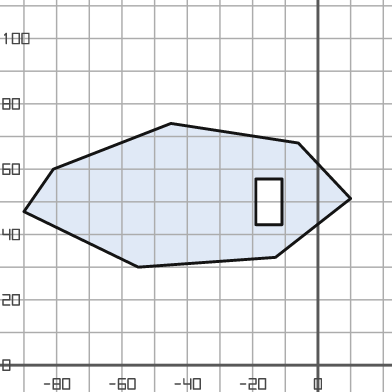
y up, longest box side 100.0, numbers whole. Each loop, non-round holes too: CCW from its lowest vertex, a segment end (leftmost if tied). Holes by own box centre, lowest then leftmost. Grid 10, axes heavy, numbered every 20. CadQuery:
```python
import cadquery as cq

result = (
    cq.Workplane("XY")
    .moveTo(-55.0, 30.0)
    .lineTo(-13.0, 33.0)
    .lineTo(10.0, 51.0)
    .lineTo(-6.0, 68.0)
    .lineTo(-45.0, 74.0)
    .lineTo(-81.0, 60.0)
    .lineTo(-90.0, 47.0)
    .close()
    .moveTo(-19.0, 43.0)
    .lineTo(-11.0, 43.0)
    .lineTo(-11.0, 57.0)
    .lineTo(-19.0, 57.0)
    .close()
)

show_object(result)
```